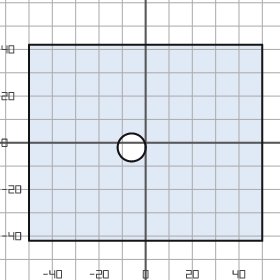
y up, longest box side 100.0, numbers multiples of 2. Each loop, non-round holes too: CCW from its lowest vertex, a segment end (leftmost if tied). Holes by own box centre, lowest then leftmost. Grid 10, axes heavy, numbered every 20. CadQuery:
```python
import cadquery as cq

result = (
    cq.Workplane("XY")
    .moveTo(-50.0, -42.0)
    .lineTo(50.0, -42.0)
    .lineTo(50.0, 42.0)
    .lineTo(-50.0, 42.0)
    .close()
    .moveTo(-6.0, -2.0)
    .circle(6.0)
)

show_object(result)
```